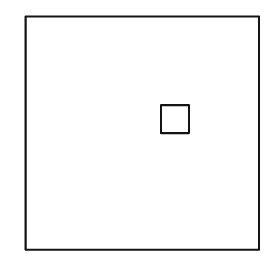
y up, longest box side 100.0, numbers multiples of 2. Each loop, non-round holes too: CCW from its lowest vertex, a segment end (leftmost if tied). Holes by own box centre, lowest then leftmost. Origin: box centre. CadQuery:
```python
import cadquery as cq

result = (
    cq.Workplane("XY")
    .moveTo(-50.0, -50.0)
    .lineTo(50.0, -50.0)
    .lineTo(50.0, 50.0)
    .lineTo(-50.0, 50.0)
    .close()
    .moveTo(8.0, 0.0)
    .lineTo(20.0, 0.0)
    .lineTo(20.0, 12.0)
    .lineTo(8.0, 12.0)
    .close()
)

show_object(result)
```